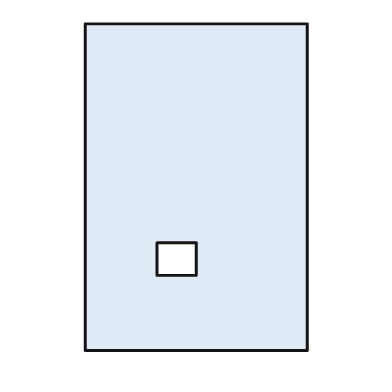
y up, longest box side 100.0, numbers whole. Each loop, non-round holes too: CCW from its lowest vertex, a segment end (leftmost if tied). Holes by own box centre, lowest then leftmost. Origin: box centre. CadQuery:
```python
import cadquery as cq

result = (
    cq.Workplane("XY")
    .moveTo(-34.0, -50.0)
    .lineTo(34.0, -50.0)
    .lineTo(34.0, 50.0)
    .lineTo(-34.0, 50.0)
    .close()
    .moveTo(-12.0, -27.0)
    .lineTo(0.0, -27.0)
    .lineTo(0.0, -17.0)
    .lineTo(-12.0, -17.0)
    .close()
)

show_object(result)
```